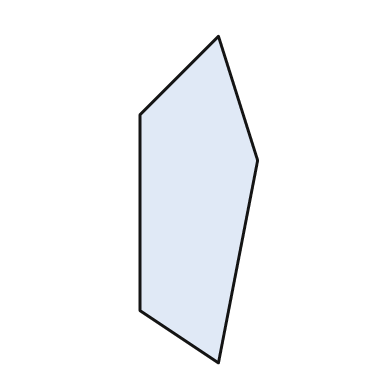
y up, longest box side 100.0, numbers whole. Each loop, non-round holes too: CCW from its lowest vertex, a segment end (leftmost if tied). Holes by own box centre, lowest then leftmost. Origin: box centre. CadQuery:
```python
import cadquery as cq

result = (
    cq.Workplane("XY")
    .moveTo(6.0, -50.0)
    .lineTo(18.0, 12.0)
    .lineTo(6.0, 50.0)
    .lineTo(-18.0, 26.0)
    .lineTo(-18.0, -34.0)
    .close()
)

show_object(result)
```